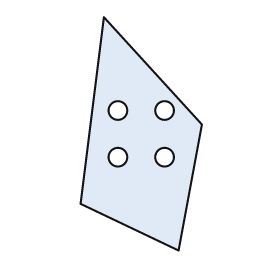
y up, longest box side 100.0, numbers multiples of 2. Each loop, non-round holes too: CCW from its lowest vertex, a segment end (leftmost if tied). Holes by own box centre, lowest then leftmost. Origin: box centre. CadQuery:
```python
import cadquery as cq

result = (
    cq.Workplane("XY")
    .moveTo(16.0, -50.0)
    .lineTo(26.0, 4.0)
    .lineTo(-16.0, 50.0)
    .lineTo(-26.0, -30.0)
    .close()
    .moveTo(-10.0, -10.0)
    .circle(4.0)
    .moveTo(10.0, -10.0)
    .circle(4.0)
    .moveTo(-10.0, 10.0)
    .circle(4.0)
    .moveTo(10.0, 10.0)
    .circle(4.0)
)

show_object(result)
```